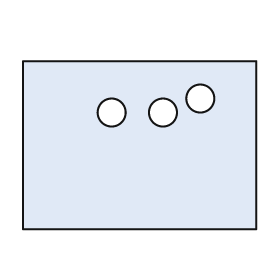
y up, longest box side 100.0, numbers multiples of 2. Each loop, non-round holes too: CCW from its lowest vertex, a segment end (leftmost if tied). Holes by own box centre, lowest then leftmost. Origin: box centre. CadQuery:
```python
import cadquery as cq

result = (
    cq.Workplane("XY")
    .moveTo(-50.0, -36.0)
    .lineTo(50.0, -36.0)
    .lineTo(50.0, 36.0)
    .lineTo(-50.0, 36.0)
    .close()
    .moveTo(-12.0, 14.0)
    .circle(6.0)
    .moveTo(10.0, 14.0)
    .circle(6.0)
    .moveTo(26.0, 20.0)
    .circle(6.0)
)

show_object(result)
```